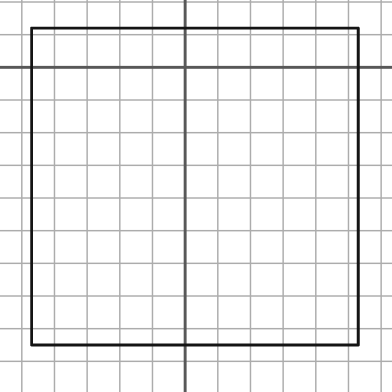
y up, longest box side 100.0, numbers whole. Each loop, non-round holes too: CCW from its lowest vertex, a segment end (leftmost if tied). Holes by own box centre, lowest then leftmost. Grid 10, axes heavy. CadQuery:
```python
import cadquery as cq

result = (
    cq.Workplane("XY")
    .moveTo(-47.0, -85.0)
    .lineTo(53.0, -85.0)
    .lineTo(53.0, 12.0)
    .lineTo(-47.0, 12.0)
    .close()
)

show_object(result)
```